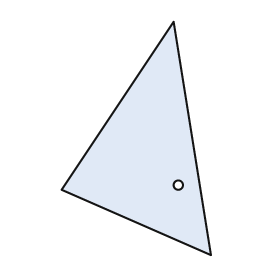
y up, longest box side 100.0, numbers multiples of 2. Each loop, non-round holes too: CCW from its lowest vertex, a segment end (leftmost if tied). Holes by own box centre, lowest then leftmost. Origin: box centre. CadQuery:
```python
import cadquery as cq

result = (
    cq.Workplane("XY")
    .moveTo(32.0, -50.0)
    .lineTo(16.0, 50.0)
    .lineTo(-32.0, -22.0)
    .close()
    .moveTo(18.0, -20.0)
    .circle(2.0)
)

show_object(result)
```